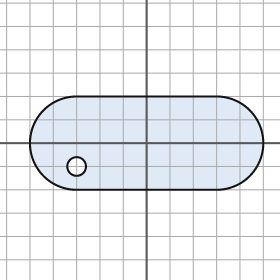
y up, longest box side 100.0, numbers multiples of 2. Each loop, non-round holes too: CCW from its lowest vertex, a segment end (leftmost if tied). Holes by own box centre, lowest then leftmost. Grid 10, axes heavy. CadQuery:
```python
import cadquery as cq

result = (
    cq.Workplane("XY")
    .moveTo(-30.0, -20.0)
    .lineTo(30.0, -20.0)
    .threePointArc((50.0, 0.0), (30.0, 20.0))
    .lineTo(-30.0, 20.0)
    .threePointArc((-50.0, 0.0), (-30.0, -20.0))
    .close()
    .moveTo(-30.0, -10.0)
    .circle(4.0)
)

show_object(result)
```